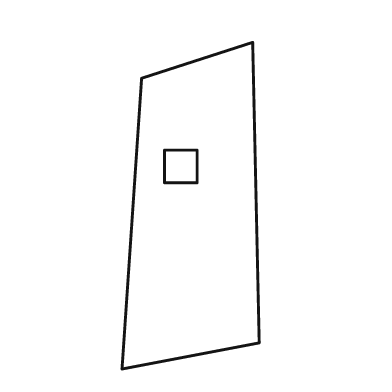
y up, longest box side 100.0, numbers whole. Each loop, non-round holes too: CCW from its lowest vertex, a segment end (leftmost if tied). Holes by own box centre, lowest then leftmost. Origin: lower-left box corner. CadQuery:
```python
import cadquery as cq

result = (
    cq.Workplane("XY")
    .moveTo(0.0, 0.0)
    .lineTo(42.0, 8.0)
    .lineTo(40.0, 100.0)
    .lineTo(6.0, 89.0)
    .close()
    .moveTo(13.0, 57.0)
    .lineTo(23.0, 57.0)
    .lineTo(23.0, 67.0)
    .lineTo(13.0, 67.0)
    .close()
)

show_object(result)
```